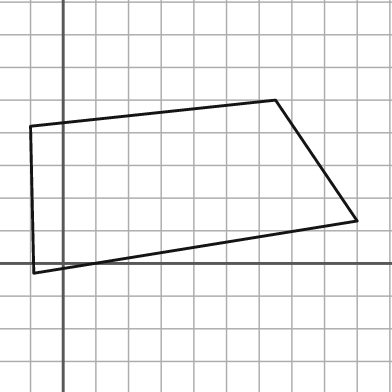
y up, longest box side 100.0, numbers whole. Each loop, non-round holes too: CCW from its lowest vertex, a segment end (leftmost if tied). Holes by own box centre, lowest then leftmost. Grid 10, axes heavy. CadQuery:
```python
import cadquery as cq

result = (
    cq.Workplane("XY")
    .moveTo(-9.0, -3.0)
    .lineTo(90.0, 13.0)
    .lineTo(65.0, 50.0)
    .lineTo(-10.0, 42.0)
    .close()
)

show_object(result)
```